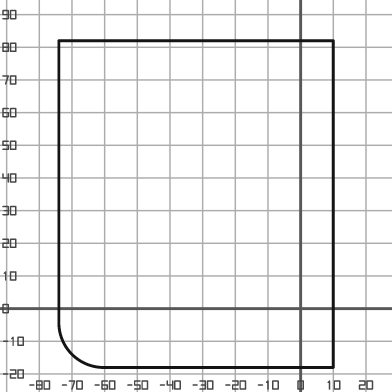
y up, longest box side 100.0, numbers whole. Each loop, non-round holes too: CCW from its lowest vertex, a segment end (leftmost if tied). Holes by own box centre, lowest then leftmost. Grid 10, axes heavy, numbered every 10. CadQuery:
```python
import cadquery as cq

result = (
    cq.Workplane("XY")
    .moveTo(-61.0, -18.0)
    .lineTo(10.0, -18.0)
    .lineTo(10.0, 82.0)
    .lineTo(-74.0, 82.0)
    .lineTo(-74.0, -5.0)
    .threePointArc((-70.0, -14.0), (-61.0, -18.0))
    .close()
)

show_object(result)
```